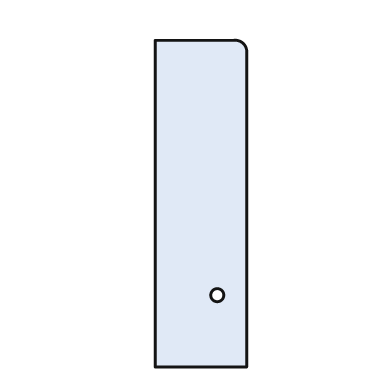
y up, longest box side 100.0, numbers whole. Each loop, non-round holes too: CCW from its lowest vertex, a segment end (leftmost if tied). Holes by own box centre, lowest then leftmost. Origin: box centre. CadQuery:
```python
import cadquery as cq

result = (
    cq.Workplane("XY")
    .moveTo(-14.0, -50.0)
    .lineTo(14.0, -50.0)
    .lineTo(14.0, 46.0)
    .threePointArc((13.0, 49.0), (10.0, 50.0))
    .lineTo(-14.0, 50.0)
    .close()
    .moveTo(5.0, -28.0)
    .circle(2.0)
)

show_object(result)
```